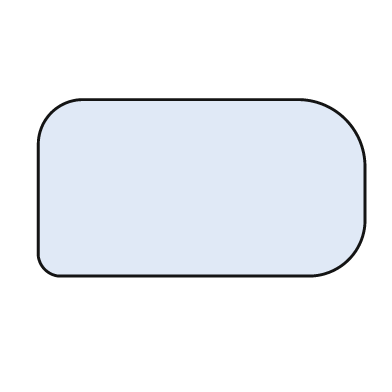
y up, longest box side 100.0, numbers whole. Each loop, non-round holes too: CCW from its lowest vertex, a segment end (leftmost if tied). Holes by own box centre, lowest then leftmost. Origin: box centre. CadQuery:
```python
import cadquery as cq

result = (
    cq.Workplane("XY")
    .moveTo(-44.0, -27.0)
    .lineTo(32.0, -27.0)
    .threePointArc((45.0, -22.0), (50.0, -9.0))
    .lineTo(50.0, 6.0)
    .threePointArc((44.0, 21.0), (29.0, 27.0))
    .lineTo(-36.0, 27.0)
    .threePointArc((-46.0, 23.0), (-50.0, 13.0))
    .lineTo(-50.0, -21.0)
    .threePointArc((-48.0, -25.0), (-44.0, -27.0))
    .close()
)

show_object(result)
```